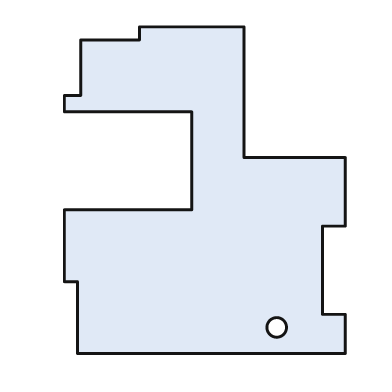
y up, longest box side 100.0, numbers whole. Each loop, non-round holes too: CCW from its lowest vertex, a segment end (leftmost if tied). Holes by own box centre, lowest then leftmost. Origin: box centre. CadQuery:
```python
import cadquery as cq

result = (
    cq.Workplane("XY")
    .moveTo(-39.0, -50.0)
    .lineTo(43.0, -50.0)
    .lineTo(43.0, -38.0)
    .lineTo(36.0, -38.0)
    .lineTo(36.0, -11.0)
    .lineTo(43.0, -11.0)
    .lineTo(43.0, 10.0)
    .lineTo(12.0, 10.0)
    .lineTo(12.0, 50.0)
    .lineTo(-20.0, 50.0)
    .lineTo(-20.0, 46.0)
    .lineTo(-38.0, 46.0)
    .lineTo(-38.0, 29.0)
    .lineTo(-43.0, 29.0)
    .lineTo(-43.0, 24.0)
    .lineTo(-4.0, 24.0)
    .lineTo(-4.0, -6.0)
    .lineTo(-43.0, -6.0)
    .lineTo(-43.0, -28.0)
    .lineTo(-39.0, -28.0)
    .close()
    .moveTo(22.0, -42.0)
    .circle(3.0)
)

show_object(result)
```